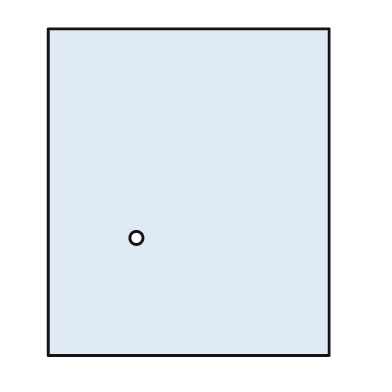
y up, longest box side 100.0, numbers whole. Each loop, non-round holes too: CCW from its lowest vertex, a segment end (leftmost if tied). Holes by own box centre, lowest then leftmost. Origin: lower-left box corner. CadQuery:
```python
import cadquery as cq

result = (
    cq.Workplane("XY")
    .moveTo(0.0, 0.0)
    .lineTo(86.0, 0.0)
    .lineTo(86.0, 100.0)
    .lineTo(0.0, 100.0)
    .close()
    .moveTo(27.0, 36.0)
    .circle(2.0)
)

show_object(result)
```